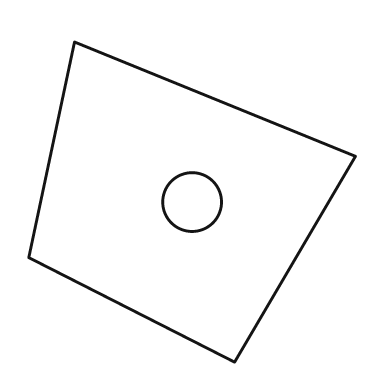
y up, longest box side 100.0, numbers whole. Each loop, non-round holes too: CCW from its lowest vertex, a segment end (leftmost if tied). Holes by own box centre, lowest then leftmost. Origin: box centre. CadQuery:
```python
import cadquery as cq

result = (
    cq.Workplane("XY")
    .moveTo(13.0, -49.0)
    .lineTo(50.0, 14.0)
    .lineTo(-36.0, 49.0)
    .lineTo(-50.0, -17.0)
    .close()
    .moveTo(0.0, 0.0)
    .circle(9.0)
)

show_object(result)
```